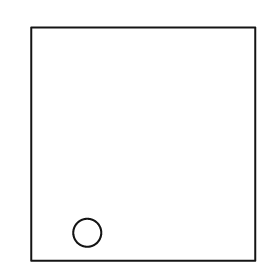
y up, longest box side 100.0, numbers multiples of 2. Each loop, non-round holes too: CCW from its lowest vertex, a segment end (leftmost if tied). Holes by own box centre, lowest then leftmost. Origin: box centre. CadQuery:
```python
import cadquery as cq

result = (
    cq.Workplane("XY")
    .moveTo(-48.0, -50.0)
    .lineTo(48.0, -50.0)
    .lineTo(48.0, 50.0)
    .lineTo(-48.0, 50.0)
    .close()
    .moveTo(-24.0, -38.0)
    .circle(6.0)
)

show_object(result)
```